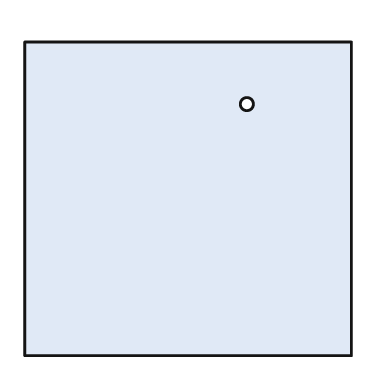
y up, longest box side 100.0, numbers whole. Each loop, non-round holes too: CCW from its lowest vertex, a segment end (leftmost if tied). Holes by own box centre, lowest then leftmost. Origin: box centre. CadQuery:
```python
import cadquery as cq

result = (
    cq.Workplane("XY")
    .moveTo(-50.0, -48.0)
    .lineTo(50.0, -48.0)
    .lineTo(50.0, 48.0)
    .lineTo(-50.0, 48.0)
    .close()
    .moveTo(18.0, 29.0)
    .circle(2.0)
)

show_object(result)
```